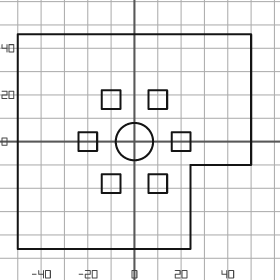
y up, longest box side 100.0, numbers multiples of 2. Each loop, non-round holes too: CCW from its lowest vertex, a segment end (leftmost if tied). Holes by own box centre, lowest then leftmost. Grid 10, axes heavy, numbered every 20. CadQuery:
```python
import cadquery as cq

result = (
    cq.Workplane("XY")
    .moveTo(-50.0, -46.0)
    .lineTo(24.0, -46.0)
    .lineTo(24.0, -10.0)
    .lineTo(50.0, -10.0)
    .lineTo(50.0, 46.0)
    .lineTo(-50.0, 46.0)
    .close()
    .moveTo(-14.0, -22.0)
    .lineTo(-6.0, -22.0)
    .lineTo(-6.0, -14.0)
    .lineTo(-14.0, -14.0)
    .close()
    .moveTo(6.0, -22.0)
    .lineTo(14.0, -22.0)
    .lineTo(14.0, -14.0)
    .lineTo(6.0, -14.0)
    .close()
    .moveTo(-24.0, -4.0)
    .lineTo(-16.0, -4.0)
    .lineTo(-16.0, 4.0)
    .lineTo(-24.0, 4.0)
    .close()
    .moveTo(0.0, 0.0)
    .circle(8.0)
    .moveTo(16.0, -4.0)
    .lineTo(24.0, -4.0)
    .lineTo(24.0, 4.0)
    .lineTo(16.0, 4.0)
    .close()
    .moveTo(-14.0, 14.0)
    .lineTo(-6.0, 14.0)
    .lineTo(-6.0, 22.0)
    .lineTo(-14.0, 22.0)
    .close()
    .moveTo(6.0, 14.0)
    .lineTo(14.0, 14.0)
    .lineTo(14.0, 22.0)
    .lineTo(6.0, 22.0)
    .close()
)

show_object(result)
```